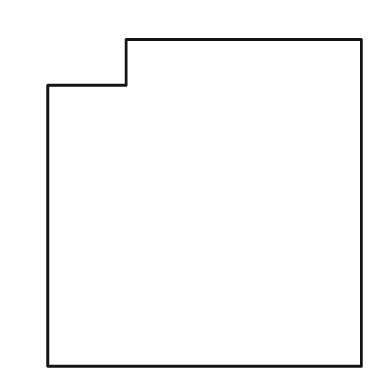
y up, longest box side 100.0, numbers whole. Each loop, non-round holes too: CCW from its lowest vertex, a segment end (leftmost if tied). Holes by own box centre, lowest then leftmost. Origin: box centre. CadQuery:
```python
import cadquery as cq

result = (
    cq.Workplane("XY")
    .moveTo(-48.0, -50.0)
    .lineTo(48.0, -50.0)
    .lineTo(48.0, 50.0)
    .lineTo(-24.0, 50.0)
    .lineTo(-24.0, 36.0)
    .lineTo(-48.0, 36.0)
    .close()
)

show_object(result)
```